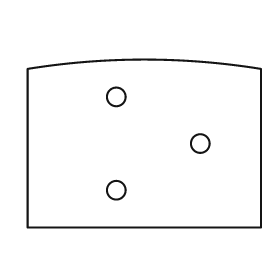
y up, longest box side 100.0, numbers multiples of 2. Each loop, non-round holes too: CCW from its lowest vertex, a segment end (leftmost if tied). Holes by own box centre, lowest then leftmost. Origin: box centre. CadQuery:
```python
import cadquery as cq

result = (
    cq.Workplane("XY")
    .moveTo(-50.0, -36.0)
    .lineTo(50.0, -36.0)
    .lineTo(50.0, 32.0)
    .threePointArc((0.0, 36.0), (-50.0, 32.0))
    .close()
    .moveTo(-12.0, -20.0)
    .circle(4.0)
    .moveTo(24.0, 0.0)
    .circle(4.0)
    .moveTo(-12.0, 20.0)
    .circle(4.0)
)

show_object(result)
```